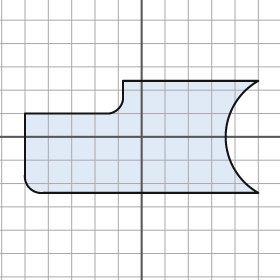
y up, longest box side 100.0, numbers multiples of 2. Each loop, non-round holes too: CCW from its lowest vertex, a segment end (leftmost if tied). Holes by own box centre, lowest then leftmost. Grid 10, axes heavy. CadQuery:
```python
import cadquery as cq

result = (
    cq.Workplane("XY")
    .moveTo(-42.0, -24.0)
    .lineTo(50.0, -24.0)
    .threePointArc((36.0, 0.0), (50.0, 24.0))
    .lineTo(-8.0, 24.0)
    .lineTo(-8.0, 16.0)
    .threePointArc((-10.0, 12.0), (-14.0, 10.0))
    .lineTo(-50.0, 10.0)
    .lineTo(-50.0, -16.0)
    .threePointArc((-48.0, -22.0), (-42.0, -24.0))
    .close()
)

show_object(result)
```